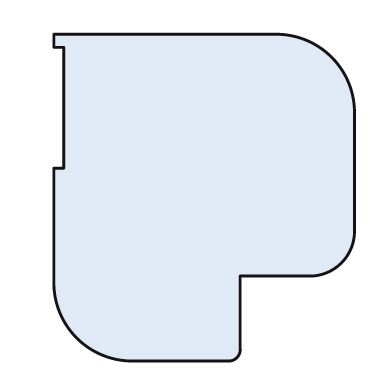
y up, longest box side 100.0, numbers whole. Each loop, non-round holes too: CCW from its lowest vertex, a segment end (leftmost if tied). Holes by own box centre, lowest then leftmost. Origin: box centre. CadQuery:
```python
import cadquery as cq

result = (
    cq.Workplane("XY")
    .moveTo(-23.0, -50.0)
    .lineTo(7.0, -50.0)
    .threePointArc((10.0, -49.0), (11.0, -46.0))
    .lineTo(11.0, -24.0)
    .lineTo(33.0, -24.0)
    .threePointArc((42.0, -20.0), (46.0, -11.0))
    .lineTo(46.0, 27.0)
    .threePointArc((39.0, 43.0), (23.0, 50.0))
    .lineTo(-46.0, 50.0)
    .lineTo(-46.0, 46.0)
    .lineTo(-43.0, 46.0)
    .lineTo(-43.0, 9.0)
    .lineTo(-46.0, 9.0)
    .lineTo(-46.0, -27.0)
    .threePointArc((-39.0, -43.0), (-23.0, -50.0))
    .close()
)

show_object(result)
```